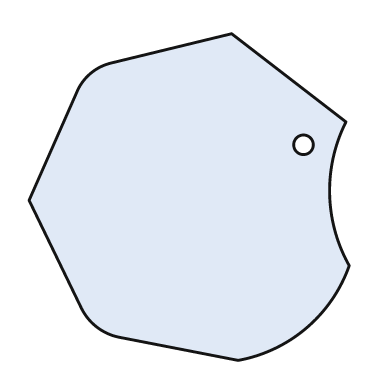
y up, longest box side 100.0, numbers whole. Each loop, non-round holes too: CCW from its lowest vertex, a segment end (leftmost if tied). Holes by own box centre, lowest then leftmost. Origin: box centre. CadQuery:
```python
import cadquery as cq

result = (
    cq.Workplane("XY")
    .moveTo(15.0, -50.0)
    .threePointArc((36.0, -40.0), (49.0, -21.0))
    .threePointArc((43.0, 1.0), (48.0, 23.0))
    .lineTo(13.0, 50.0)
    .lineTo(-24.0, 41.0)
    .threePointArc((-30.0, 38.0), (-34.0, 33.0))
    .lineTo(-49.0, -1.0)
    .lineTo(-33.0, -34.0)
    .threePointArc((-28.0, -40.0), (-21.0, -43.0))
    .close()
    .moveTo(35.0, 16.0)
    .circle(3.0)
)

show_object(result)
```